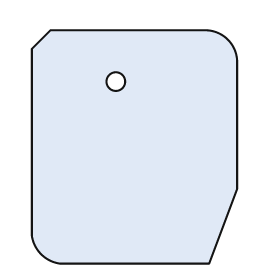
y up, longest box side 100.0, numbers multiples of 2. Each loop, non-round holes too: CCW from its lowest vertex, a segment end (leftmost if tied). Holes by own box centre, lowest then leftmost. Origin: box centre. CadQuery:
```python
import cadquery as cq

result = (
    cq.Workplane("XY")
    .moveTo(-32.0, -50.0)
    .lineTo(32.0, -50.0)
    .lineTo(44.0, -18.0)
    .lineTo(44.0, 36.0)
    .threePointArc((40.0, 46.0), (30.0, 50.0))
    .lineTo(-36.0, 50.0)
    .lineTo(-44.0, 42.0)
    .lineTo(-44.0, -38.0)
    .threePointArc((-40.0, -46.0), (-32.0, -50.0))
    .close()
    .moveTo(-8.0, 28.0)
    .circle(4.0)
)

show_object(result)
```